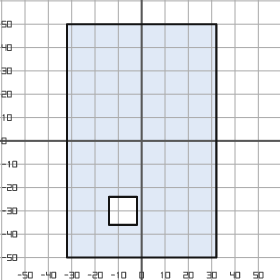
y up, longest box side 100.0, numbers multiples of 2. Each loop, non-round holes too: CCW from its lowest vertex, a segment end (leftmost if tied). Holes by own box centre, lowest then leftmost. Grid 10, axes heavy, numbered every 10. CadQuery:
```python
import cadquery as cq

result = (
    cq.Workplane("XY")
    .moveTo(-32.0, -50.0)
    .lineTo(32.0, -50.0)
    .lineTo(32.0, 50.0)
    .lineTo(-32.0, 50.0)
    .close()
    .moveTo(-14.0, -36.0)
    .lineTo(-2.0, -36.0)
    .lineTo(-2.0, -24.0)
    .lineTo(-14.0, -24.0)
    .close()
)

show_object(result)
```